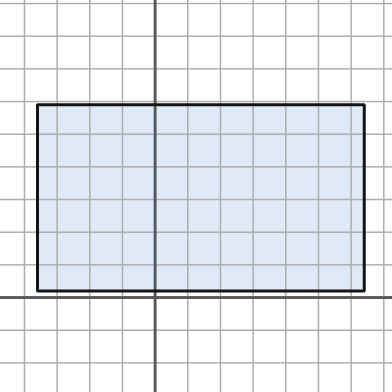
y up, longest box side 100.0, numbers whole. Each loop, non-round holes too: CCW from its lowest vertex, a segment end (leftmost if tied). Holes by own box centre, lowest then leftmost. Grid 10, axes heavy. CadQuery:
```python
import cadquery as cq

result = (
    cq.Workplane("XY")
    .moveTo(-36.0, 2.0)
    .lineTo(64.0, 2.0)
    .lineTo(64.0, 59.0)
    .lineTo(-36.0, 59.0)
    .close()
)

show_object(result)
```